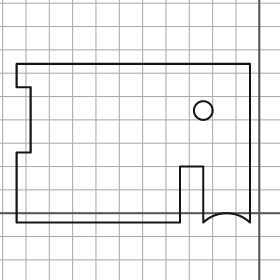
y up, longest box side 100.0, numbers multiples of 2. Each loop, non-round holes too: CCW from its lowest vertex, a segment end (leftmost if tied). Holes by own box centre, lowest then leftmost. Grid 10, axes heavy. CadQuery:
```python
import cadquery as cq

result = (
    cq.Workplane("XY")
    .moveTo(-104.0, -4.0)
    .lineTo(-34.0, -4.0)
    .lineTo(-34.0, 20.0)
    .lineTo(-24.0, 20.0)
    .lineTo(-24.0, -4.0)
    .threePointArc((-14.0, 0.0), (-4.0, -4.0))
    .lineTo(-4.0, 64.0)
    .lineTo(-104.0, 64.0)
    .lineTo(-104.0, 54.0)
    .lineTo(-98.0, 54.0)
    .lineTo(-98.0, 26.0)
    .lineTo(-104.0, 26.0)
    .close()
    .moveTo(-24.0, 44.0)
    .circle(4.0)
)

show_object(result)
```